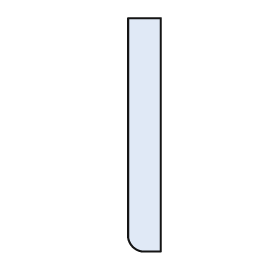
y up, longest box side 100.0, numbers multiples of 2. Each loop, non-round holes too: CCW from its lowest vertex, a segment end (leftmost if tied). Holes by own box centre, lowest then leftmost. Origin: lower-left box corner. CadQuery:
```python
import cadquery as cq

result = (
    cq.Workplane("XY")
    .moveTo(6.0, 0.0)
    .lineTo(14.0, 0.0)
    .lineTo(14.0, 100.0)
    .lineTo(0.0, 100.0)
    .lineTo(0.0, 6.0)
    .threePointArc((2.0, 2.0), (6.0, 0.0))
    .close()
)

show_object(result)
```